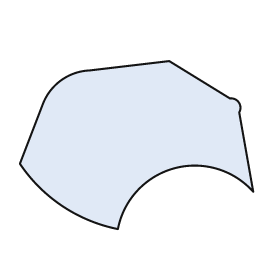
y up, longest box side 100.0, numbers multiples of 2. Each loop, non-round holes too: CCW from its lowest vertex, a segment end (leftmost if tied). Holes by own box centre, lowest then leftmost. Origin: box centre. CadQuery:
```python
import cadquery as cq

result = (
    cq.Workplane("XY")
    .moveTo(-8.0, -36.0)
    .threePointArc((16.0, -10.0), (50.0, -20.0))
    .lineTo(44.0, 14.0)
    .threePointArc((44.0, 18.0), (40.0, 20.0))
    .lineTo(14.0, 36.0)
    .lineTo(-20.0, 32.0)
    .threePointArc((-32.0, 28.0), (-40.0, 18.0))
    .lineTo(-50.0, -8.0)
    .threePointArc((-32.0, -26.0), (-8.0, -36.0))
    .close()
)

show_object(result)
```